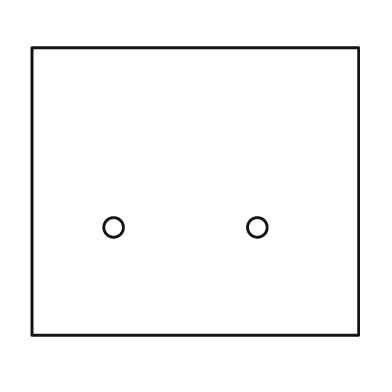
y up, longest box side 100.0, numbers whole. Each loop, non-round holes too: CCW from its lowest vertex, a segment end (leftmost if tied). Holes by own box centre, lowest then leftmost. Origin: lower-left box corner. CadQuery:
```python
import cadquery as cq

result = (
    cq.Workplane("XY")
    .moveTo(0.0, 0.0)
    .lineTo(100.0, 0.0)
    .lineTo(100.0, 88.0)
    .lineTo(0.0, 88.0)
    .close()
    .moveTo(25.0, 33.0)
    .circle(3.0)
    .moveTo(69.0, 33.0)
    .circle(3.0)
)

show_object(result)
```